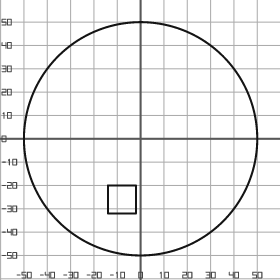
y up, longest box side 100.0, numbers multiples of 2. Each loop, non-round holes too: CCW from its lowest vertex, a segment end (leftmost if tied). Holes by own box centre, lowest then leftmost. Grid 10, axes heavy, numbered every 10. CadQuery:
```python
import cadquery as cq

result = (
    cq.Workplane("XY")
    .moveTo(0.0, 0.0)
    .circle(50.0)
    .moveTo(-14.0, -32.0)
    .lineTo(-2.0, -32.0)
    .lineTo(-2.0, -20.0)
    .lineTo(-14.0, -20.0)
    .close()
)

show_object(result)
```